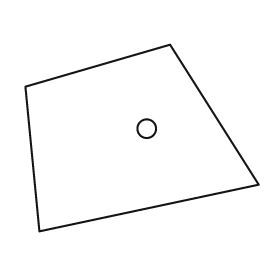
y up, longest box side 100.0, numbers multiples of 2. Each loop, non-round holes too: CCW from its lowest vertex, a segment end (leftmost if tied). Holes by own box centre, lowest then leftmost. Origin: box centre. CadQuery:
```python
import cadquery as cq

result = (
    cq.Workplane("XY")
    .moveTo(-44.0, -40.0)
    .lineTo(50.0, -20.0)
    .lineTo(12.0, 40.0)
    .lineTo(-50.0, 22.0)
    .close()
    .moveTo(2.0, 4.0)
    .circle(4.0)
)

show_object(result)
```